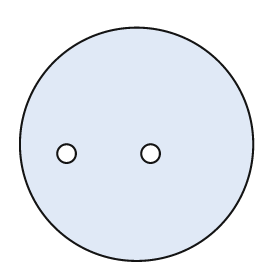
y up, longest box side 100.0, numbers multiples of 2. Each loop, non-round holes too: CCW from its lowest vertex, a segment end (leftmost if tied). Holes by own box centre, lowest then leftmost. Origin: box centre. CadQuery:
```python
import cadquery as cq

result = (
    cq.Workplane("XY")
    .moveTo(0.0, 0.0)
    .circle(50.0)
    .moveTo(-30.0, -4.0)
    .circle(4.0)
    .moveTo(6.0, -4.0)
    .circle(4.0)
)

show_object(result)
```